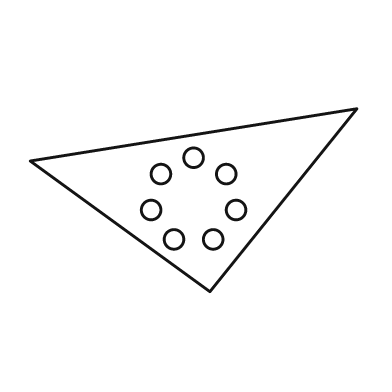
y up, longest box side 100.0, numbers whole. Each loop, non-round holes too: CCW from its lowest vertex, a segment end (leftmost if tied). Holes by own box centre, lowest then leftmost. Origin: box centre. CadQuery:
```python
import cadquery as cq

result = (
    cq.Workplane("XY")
    .moveTo(5.0, -28.0)
    .lineTo(50.0, 28.0)
    .lineTo(-50.0, 12.0)
    .close()
    .moveTo(-6.0, -12.0)
    .circle(3.0)
    .moveTo(6.0, -12.0)
    .circle(3.0)
    .moveTo(-13.0, -3.0)
    .circle(3.0)
    .moveTo(13.0, -3.0)
    .circle(3.0)
    .moveTo(-10.0, 8.0)
    .circle(3.0)
    .moveTo(10.0, 8.0)
    .circle(3.0)
    .moveTo(0.0, 13.0)
    .circle(3.0)
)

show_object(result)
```